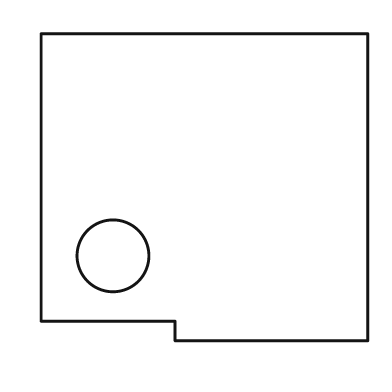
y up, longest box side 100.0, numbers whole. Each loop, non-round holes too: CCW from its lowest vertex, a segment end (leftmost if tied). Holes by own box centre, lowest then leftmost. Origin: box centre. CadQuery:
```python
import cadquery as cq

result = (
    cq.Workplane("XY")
    .moveTo(-9.0, -47.0)
    .lineTo(50.0, -47.0)
    .lineTo(50.0, 47.0)
    .lineTo(-50.0, 47.0)
    .lineTo(-50.0, -41.0)
    .lineTo(-9.0, -41.0)
    .close()
    .moveTo(-28.0, -21.0)
    .circle(11.0)
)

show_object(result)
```